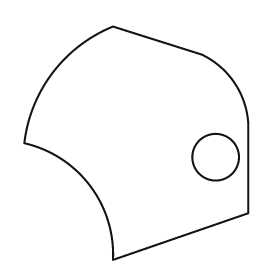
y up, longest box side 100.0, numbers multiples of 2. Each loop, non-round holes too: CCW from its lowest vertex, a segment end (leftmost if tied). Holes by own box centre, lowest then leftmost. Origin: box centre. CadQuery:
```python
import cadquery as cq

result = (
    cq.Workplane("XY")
    .moveTo(-10.0, -50.0)
    .lineTo(48.0, -30.0)
    .lineTo(48.0, 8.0)
    .threePointArc((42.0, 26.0), (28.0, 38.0))
    .lineTo(-10.0, 50.0)
    .threePointArc((-36.0, 30.0), (-48.0, 0.0))
    .threePointArc((-20.0, -18.0), (-10.0, -50.0))
    .close()
    .moveTo(34.0, -6.0)
    .circle(10.0)
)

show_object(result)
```